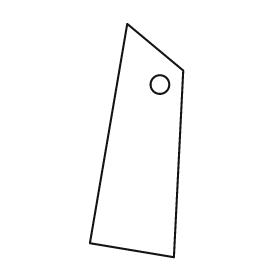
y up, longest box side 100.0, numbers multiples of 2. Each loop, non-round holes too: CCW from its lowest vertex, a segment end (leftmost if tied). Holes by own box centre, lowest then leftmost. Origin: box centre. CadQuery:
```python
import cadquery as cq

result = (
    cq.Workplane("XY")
    .moveTo(16.0, -50.0)
    .lineTo(20.0, 30.0)
    .lineTo(-4.0, 50.0)
    .lineTo(-20.0, -44.0)
    .close()
    .moveTo(10.0, 24.0)
    .circle(4.0)
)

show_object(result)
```